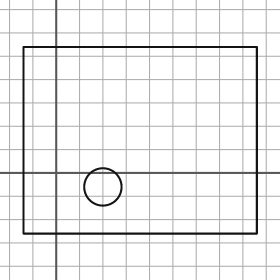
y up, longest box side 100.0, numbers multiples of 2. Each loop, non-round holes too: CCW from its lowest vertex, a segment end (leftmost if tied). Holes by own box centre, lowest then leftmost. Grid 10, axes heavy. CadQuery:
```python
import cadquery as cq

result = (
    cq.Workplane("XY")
    .moveTo(-14.0, -26.0)
    .lineTo(86.0, -26.0)
    .lineTo(86.0, 54.0)
    .lineTo(-14.0, 54.0)
    .close()
    .moveTo(20.0, -6.0)
    .circle(8.0)
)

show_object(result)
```